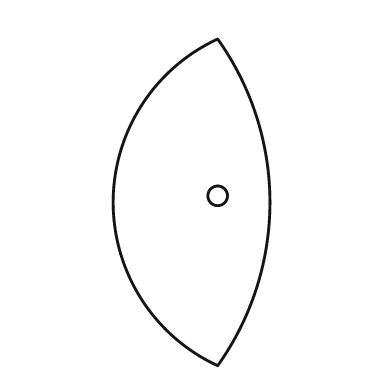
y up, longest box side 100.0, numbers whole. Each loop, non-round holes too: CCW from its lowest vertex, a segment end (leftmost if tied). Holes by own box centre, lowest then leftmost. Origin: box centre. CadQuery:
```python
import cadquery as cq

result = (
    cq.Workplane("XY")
    .moveTo(8.0, -50.0)
    .threePointArc((24.0, 0.0), (8.0, 50.0))
    .threePointArc((-24.0, 0.0), (8.0, -50.0))
    .close()
    .moveTo(8.0, 2.0)
    .circle(3.0)
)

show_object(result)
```